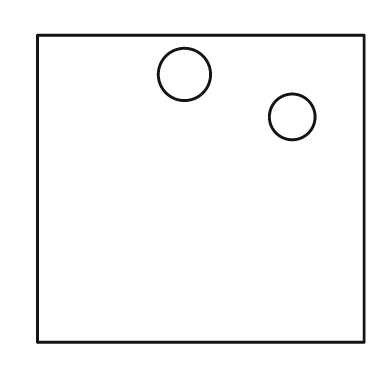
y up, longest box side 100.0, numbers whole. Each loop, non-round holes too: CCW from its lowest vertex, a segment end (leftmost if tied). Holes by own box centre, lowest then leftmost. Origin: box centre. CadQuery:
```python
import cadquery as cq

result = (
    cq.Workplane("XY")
    .moveTo(-50.0, -47.0)
    .lineTo(50.0, -47.0)
    .lineTo(50.0, 47.0)
    .lineTo(-50.0, 47.0)
    .close()
    .moveTo(28.0, 22.0)
    .circle(7.0)
    .moveTo(-5.0, 35.0)
    .circle(8.0)
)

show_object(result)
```